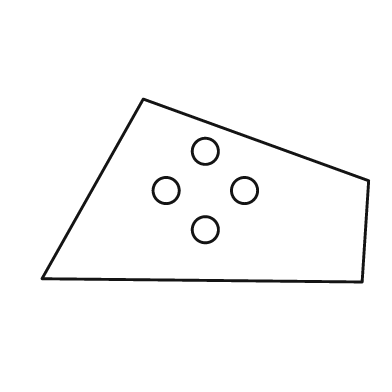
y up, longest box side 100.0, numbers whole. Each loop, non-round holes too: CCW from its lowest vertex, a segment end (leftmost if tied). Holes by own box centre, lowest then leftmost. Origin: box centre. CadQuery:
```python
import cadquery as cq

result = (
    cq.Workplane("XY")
    .moveTo(48.0, -28.0)
    .lineTo(50.0, 3.0)
    .lineTo(-19.0, 28.0)
    .lineTo(-50.0, -27.0)
    .close()
    .moveTo(0.0, -12.0)
    .circle(4.0)
    .moveTo(-12.0, 0.0)
    .circle(4.0)
    .moveTo(12.0, 0.0)
    .circle(4.0)
    .moveTo(0.0, 12.0)
    .circle(4.0)
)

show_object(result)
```